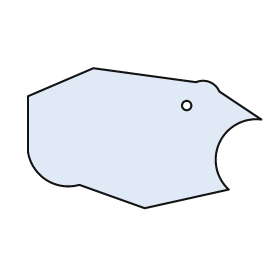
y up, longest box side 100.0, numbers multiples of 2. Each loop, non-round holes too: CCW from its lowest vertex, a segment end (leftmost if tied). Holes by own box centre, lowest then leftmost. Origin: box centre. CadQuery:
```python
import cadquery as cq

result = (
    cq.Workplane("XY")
    .moveTo(0.0, -30.0)
    .lineTo(36.0, -22.0)
    .threePointArc((32.0, -2.0), (50.0, 8.0))
    .lineTo(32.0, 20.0)
    .threePointArc((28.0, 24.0), (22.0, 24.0))
    .lineTo(-22.0, 30.0)
    .lineTo(-50.0, 18.0)
    .lineTo(-50.0, -6.0)
    .threePointArc((-42.0, -18.0), (-28.0, -20.0))
    .close()
    .moveTo(18.0, 14.0)
    .circle(2.0)
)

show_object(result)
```